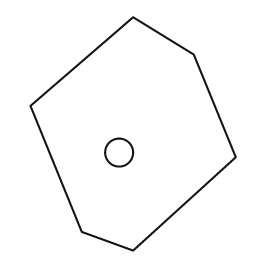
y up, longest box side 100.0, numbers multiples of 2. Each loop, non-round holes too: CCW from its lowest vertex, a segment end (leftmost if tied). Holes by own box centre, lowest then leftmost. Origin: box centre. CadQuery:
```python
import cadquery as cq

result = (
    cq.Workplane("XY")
    .moveTo(0.0, -50.0)
    .lineTo(44.0, -10.0)
    .lineTo(26.0, 34.0)
    .lineTo(0.0, 50.0)
    .lineTo(-44.0, 12.0)
    .lineTo(-22.0, -42.0)
    .close()
    .moveTo(-6.0, -8.0)
    .circle(6.0)
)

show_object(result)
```